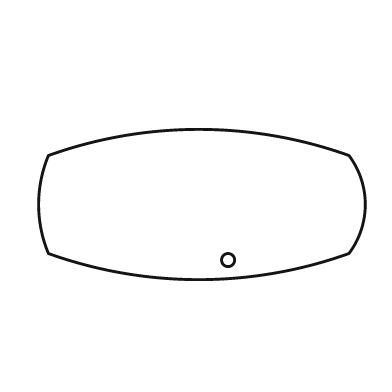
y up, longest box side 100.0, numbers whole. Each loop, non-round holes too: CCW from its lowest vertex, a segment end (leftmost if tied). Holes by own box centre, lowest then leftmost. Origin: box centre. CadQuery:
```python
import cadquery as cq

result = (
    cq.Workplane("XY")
    .moveTo(-47.0, -15.0)
    .threePointArc((-1.0, -23.0), (45.0, -15.0))
    .threePointArc((50.0, 0.0), (45.0, 15.0))
    .threePointArc((-1.0, 23.0), (-47.0, 15.0))
    .threePointArc((-50.0, 0.0), (-47.0, -15.0))
    .close()
    .moveTo(8.0, -17.0)
    .circle(2.0)
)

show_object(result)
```